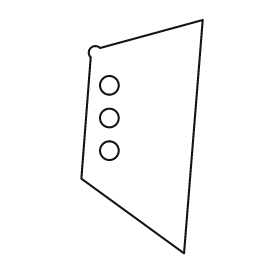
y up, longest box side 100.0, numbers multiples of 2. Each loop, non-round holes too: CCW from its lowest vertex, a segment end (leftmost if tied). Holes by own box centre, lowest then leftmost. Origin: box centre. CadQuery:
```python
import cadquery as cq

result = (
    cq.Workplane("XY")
    .moveTo(18.0, -50.0)
    .lineTo(26.0, 50.0)
    .lineTo(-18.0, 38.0)
    .threePointArc((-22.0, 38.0), (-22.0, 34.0))
    .lineTo(-26.0, -18.0)
    .close()
    .moveTo(-14.0, -6.0)
    .circle(4.0)
    .moveTo(-14.0, 8.0)
    .circle(4.0)
    .moveTo(-14.0, 22.0)
    .circle(4.0)
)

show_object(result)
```